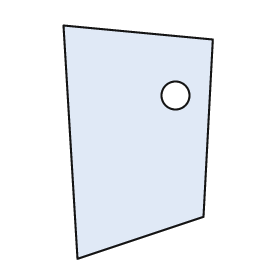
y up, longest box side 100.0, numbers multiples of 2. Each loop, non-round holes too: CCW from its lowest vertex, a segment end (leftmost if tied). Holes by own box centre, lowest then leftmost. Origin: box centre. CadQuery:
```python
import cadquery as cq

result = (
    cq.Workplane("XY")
    .moveTo(-26.0, -50.0)
    .lineTo(28.0, -32.0)
    .lineTo(32.0, 44.0)
    .lineTo(-32.0, 50.0)
    .close()
    .moveTo(16.0, 20.0)
    .circle(6.0)
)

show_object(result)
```